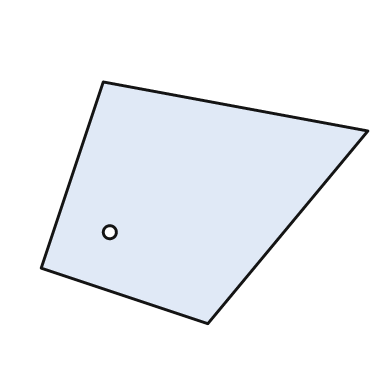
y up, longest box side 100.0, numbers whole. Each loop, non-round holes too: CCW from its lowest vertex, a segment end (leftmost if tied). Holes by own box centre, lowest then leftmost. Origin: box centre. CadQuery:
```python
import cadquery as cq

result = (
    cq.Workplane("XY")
    .moveTo(1.0, -37.0)
    .lineTo(50.0, 22.0)
    .lineTo(-31.0, 37.0)
    .lineTo(-50.0, -20.0)
    .close()
    .moveTo(-29.0, -9.0)
    .circle(2.0)
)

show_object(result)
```